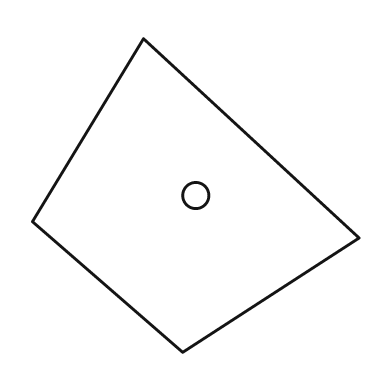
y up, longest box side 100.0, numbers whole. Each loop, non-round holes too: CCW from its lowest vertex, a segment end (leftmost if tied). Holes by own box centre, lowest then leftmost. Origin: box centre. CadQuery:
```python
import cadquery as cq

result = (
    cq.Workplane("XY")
    .moveTo(-4.0, -48.0)
    .lineTo(50.0, -13.0)
    .lineTo(-16.0, 48.0)
    .lineTo(-50.0, -8.0)
    .close()
    .moveTo(0.0, 0.0)
    .circle(4.0)
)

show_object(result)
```